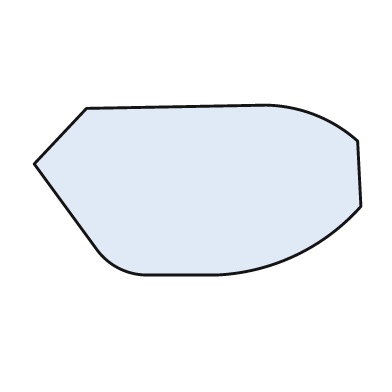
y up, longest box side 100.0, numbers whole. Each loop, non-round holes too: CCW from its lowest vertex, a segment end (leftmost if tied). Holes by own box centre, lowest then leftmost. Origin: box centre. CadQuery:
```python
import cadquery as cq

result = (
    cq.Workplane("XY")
    .moveTo(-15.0, -26.0)
    .lineTo(6.0, -26.0)
    .threePointArc((30.0, -20.0), (50.0, -5.0))
    .lineTo(49.0, 15.0)
    .threePointArc((36.0, 23.0), (21.0, 26.0))
    .lineTo(-34.0, 25.0)
    .lineTo(-50.0, 8.0)
    .lineTo(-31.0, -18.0)
    .threePointArc((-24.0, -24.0), (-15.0, -26.0))
    .close()
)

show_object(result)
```